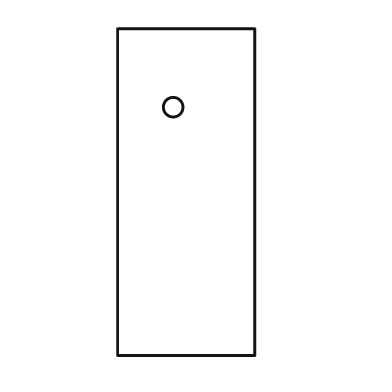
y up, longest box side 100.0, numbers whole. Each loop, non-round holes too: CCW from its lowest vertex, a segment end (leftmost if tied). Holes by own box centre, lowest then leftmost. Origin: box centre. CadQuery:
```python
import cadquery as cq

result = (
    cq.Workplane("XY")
    .moveTo(-21.0, -50.0)
    .lineTo(21.0, -50.0)
    .lineTo(21.0, 50.0)
    .lineTo(-21.0, 50.0)
    .close()
    .moveTo(-4.0, 26.0)
    .circle(3.0)
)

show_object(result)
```